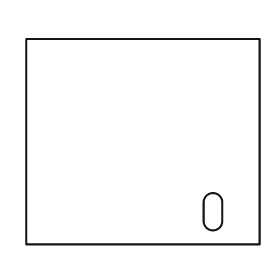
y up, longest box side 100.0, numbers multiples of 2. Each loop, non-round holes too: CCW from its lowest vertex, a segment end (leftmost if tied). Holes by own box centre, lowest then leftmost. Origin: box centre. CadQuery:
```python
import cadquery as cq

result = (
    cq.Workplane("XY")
    .moveTo(-50.0, -44.0)
    .lineTo(50.0, -44.0)
    .lineTo(50.0, 44.0)
    .lineTo(-50.0, 44.0)
    .close()
    .moveTo(26.0, -34.0)
    .threePointArc((30.0, -38.0), (34.0, -34.0))
    .lineTo(34.0, -26.0)
    .threePointArc((30.0, -22.0), (26.0, -26.0))
    .close()
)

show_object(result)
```